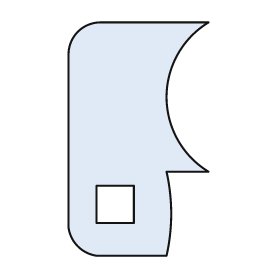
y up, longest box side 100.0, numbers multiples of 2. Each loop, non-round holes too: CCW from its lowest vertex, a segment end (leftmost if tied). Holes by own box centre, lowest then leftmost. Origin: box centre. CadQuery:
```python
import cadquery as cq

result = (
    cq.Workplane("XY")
    .moveTo(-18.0, -50.0)
    .lineTo(12.0, -50.0)
    .threePointArc((14.0, -32.0), (12.0, -14.0))
    .lineTo(30.0, -14.0)
    .threePointArc((12.0, 18.0), (30.0, 50.0))
    .lineTo(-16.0, 50.0)
    .threePointArc((-26.0, 46.0), (-30.0, 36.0))
    .lineTo(-30.0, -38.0)
    .threePointArc((-26.0, -46.0), (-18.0, -50.0))
    .close()
    .moveTo(-18.0, -36.0)
    .lineTo(-2.0, -36.0)
    .lineTo(-2.0, -20.0)
    .lineTo(-18.0, -20.0)
    .close()
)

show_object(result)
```